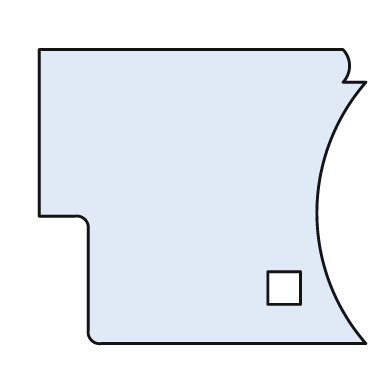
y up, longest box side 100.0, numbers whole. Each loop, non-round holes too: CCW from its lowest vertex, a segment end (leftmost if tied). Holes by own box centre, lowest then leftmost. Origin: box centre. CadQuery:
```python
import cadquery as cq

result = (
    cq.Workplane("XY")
    .moveTo(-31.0, -45.0)
    .lineTo(50.0, -45.0)
    .threePointArc((35.0, -5.0), (50.0, 35.0))
    .lineTo(43.0, 35.0)
    .threePointArc((45.0, 40.0), (43.0, 45.0))
    .lineTo(-50.0, 45.0)
    .lineTo(-50.0, -6.0)
    .lineTo(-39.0, -6.0)
    .threePointArc((-36.0, -7.0), (-35.0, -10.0))
    .lineTo(-35.0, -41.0)
    .threePointArc((-34.0, -44.0), (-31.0, -45.0))
    .close()
    .moveTo(20.0, -33.0)
    .lineTo(30.0, -33.0)
    .lineTo(30.0, -23.0)
    .lineTo(20.0, -23.0)
    .close()
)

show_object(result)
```